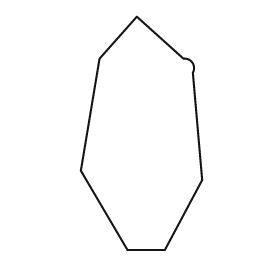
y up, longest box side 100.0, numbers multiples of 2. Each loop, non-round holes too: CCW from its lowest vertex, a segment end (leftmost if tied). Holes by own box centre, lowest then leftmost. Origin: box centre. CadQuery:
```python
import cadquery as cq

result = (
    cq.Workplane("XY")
    .moveTo(-6.0, -50.0)
    .lineTo(10.0, -50.0)
    .lineTo(26.0, -20.0)
    .lineTo(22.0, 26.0)
    .threePointArc((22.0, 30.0), (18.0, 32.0))
    .lineTo(-2.0, 50.0)
    .lineTo(-18.0, 32.0)
    .lineTo(-26.0, -16.0)
    .close()
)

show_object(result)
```